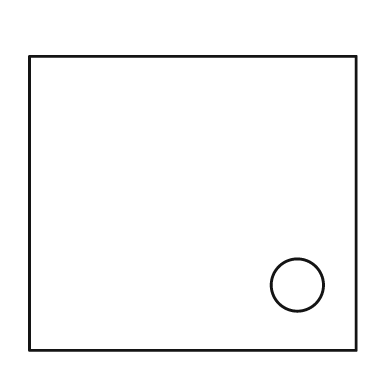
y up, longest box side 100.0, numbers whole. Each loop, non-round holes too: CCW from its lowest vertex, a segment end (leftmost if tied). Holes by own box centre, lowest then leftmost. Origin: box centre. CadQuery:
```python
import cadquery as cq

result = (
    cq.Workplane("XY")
    .moveTo(-50.0, -45.0)
    .lineTo(50.0, -45.0)
    .lineTo(50.0, 45.0)
    .lineTo(-50.0, 45.0)
    .close()
    .moveTo(32.0, -25.0)
    .circle(8.0)
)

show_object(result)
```